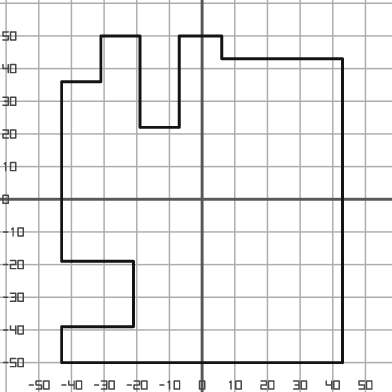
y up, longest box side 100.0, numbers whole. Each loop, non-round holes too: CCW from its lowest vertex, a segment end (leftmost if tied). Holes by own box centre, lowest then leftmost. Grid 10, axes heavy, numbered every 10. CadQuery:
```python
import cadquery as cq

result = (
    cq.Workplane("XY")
    .moveTo(-43.0, -50.0)
    .lineTo(43.0, -50.0)
    .lineTo(43.0, 43.0)
    .lineTo(6.0, 43.0)
    .lineTo(6.0, 50.0)
    .lineTo(-7.0, 50.0)
    .lineTo(-7.0, 22.0)
    .lineTo(-19.0, 22.0)
    .lineTo(-19.0, 50.0)
    .lineTo(-31.0, 50.0)
    .lineTo(-31.0, 36.0)
    .lineTo(-43.0, 36.0)
    .lineTo(-43.0, -19.0)
    .lineTo(-21.0, -19.0)
    .lineTo(-21.0, -39.0)
    .lineTo(-43.0, -39.0)
    .close()
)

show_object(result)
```